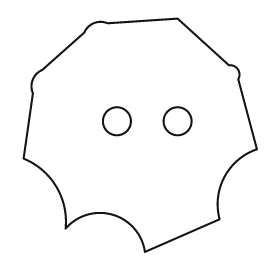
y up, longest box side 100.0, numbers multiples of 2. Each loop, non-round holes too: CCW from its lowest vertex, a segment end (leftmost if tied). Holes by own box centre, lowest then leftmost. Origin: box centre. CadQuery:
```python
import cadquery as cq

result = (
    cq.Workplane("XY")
    .moveTo(2.0, -50.0)
    .lineTo(34.0, -36.0)
    .threePointArc((36.0, -18.0), (50.0, -6.0))
    .lineTo(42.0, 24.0)
    .threePointArc((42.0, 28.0), (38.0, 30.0))
    .lineTo(16.0, 50.0)
    .lineTo(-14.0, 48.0)
    .threePointArc((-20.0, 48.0), (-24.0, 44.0))
    .lineTo(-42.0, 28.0)
    .threePointArc((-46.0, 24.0), (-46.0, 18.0))
    .lineTo(-50.0, -10.0)
    .threePointArc((-36.0, -22.0), (-32.0, -40.0))
    .threePointArc((-12.0, -34.0), (2.0, -50.0))
    .close()
    .moveTo(-10.0, 6.0)
    .circle(6.0)
    .moveTo(16.0, 6.0)
    .circle(6.0)
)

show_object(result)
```